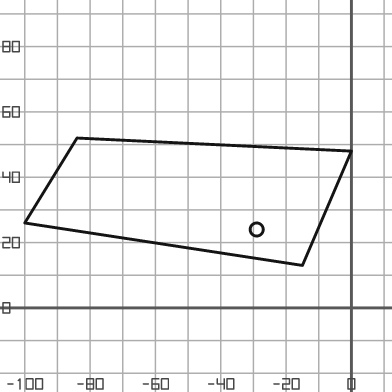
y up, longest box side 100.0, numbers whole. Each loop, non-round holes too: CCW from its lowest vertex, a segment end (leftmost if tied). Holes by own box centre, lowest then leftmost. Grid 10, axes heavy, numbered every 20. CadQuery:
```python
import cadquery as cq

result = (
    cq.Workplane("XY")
    .moveTo(-15.0, 13.0)
    .lineTo(0.0, 48.0)
    .lineTo(-84.0, 52.0)
    .lineTo(-100.0, 26.0)
    .close()
    .moveTo(-29.0, 24.0)
    .circle(2.0)
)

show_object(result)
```